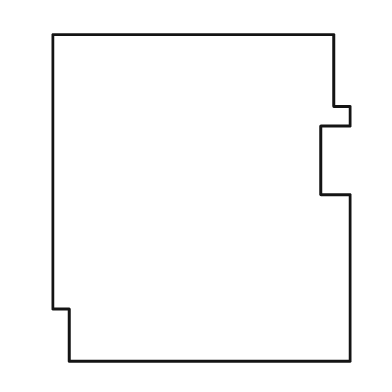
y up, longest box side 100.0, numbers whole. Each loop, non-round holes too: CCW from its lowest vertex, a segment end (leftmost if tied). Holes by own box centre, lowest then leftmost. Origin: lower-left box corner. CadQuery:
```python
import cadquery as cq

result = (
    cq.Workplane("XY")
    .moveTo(5.0, 0.0)
    .lineTo(91.0, 0.0)
    .lineTo(91.0, 51.0)
    .lineTo(82.0, 51.0)
    .lineTo(82.0, 72.0)
    .lineTo(91.0, 72.0)
    .lineTo(91.0, 78.0)
    .lineTo(86.0, 78.0)
    .lineTo(86.0, 100.0)
    .lineTo(0.0, 100.0)
    .lineTo(0.0, 16.0)
    .lineTo(5.0, 16.0)
    .close()
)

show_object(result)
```